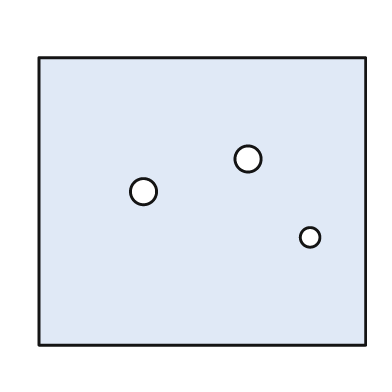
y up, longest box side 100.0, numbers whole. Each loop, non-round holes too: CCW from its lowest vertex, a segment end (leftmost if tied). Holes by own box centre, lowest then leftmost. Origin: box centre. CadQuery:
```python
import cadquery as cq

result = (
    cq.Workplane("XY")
    .moveTo(-50.0, -44.0)
    .lineTo(50.0, -44.0)
    .lineTo(50.0, 44.0)
    .lineTo(-50.0, 44.0)
    .close()
    .moveTo(33.0, -11.0)
    .circle(3.0)
    .moveTo(-18.0, 3.0)
    .circle(4.0)
    .moveTo(14.0, 13.0)
    .circle(4.0)
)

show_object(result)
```